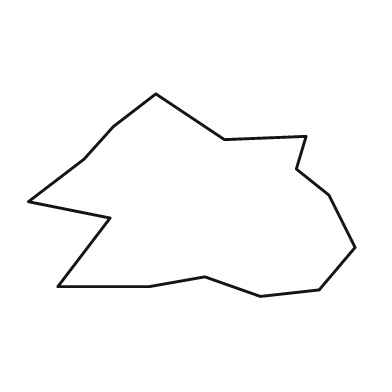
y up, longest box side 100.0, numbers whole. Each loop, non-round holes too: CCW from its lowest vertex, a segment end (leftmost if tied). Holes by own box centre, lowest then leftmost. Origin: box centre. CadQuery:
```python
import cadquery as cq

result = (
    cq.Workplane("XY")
    .moveTo(21.0, -31.0)
    .lineTo(39.0, -29.0)
    .lineTo(50.0, -16.0)
    .lineTo(42.0, 0.0)
    .lineTo(32.0, 8.0)
    .lineTo(35.0, 18.0)
    .lineTo(10.0, 17.0)
    .lineTo(-11.0, 31.0)
    .lineTo(-24.0, 21.0)
    .lineTo(-33.0, 11.0)
    .lineTo(-50.0, -2.0)
    .lineTo(-25.0, -7.0)
    .lineTo(-41.0, -28.0)
    .lineTo(-13.0, -28.0)
    .lineTo(4.0, -25.0)
    .close()
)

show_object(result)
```